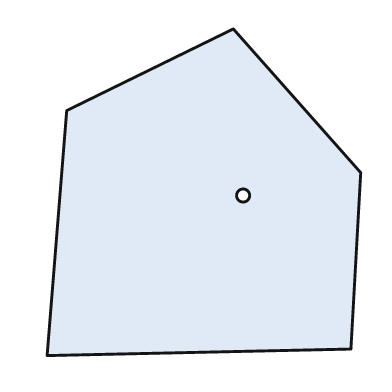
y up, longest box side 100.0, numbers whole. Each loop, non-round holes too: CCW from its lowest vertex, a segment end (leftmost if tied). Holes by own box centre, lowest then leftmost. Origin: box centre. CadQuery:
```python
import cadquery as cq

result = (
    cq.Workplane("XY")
    .moveTo(-48.0, -50.0)
    .lineTo(45.0, -48.0)
    .lineTo(48.0, 6.0)
    .lineTo(9.0, 50.0)
    .lineTo(-42.0, 25.0)
    .close()
    .moveTo(12.0, -1.0)
    .circle(2.0)
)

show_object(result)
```